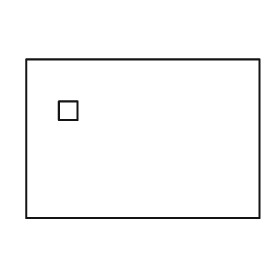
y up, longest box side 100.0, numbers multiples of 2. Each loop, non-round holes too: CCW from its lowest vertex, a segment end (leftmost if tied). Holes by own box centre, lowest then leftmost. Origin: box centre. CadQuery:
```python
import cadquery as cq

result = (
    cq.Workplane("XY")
    .moveTo(-50.0, -34.0)
    .lineTo(50.0, -34.0)
    .lineTo(50.0, 34.0)
    .lineTo(-50.0, 34.0)
    .close()
    .moveTo(-36.0, 8.0)
    .lineTo(-28.0, 8.0)
    .lineTo(-28.0, 16.0)
    .lineTo(-36.0, 16.0)
    .close()
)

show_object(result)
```